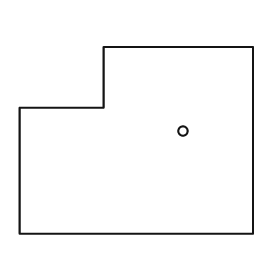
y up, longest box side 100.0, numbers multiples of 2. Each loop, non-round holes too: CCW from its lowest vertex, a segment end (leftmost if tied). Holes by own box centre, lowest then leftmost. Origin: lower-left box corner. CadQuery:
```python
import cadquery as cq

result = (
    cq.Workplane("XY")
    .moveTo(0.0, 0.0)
    .lineTo(100.0, 0.0)
    .lineTo(100.0, 80.0)
    .lineTo(36.0, 80.0)
    .lineTo(36.0, 54.0)
    .lineTo(0.0, 54.0)
    .close()
    .moveTo(70.0, 44.0)
    .circle(2.0)
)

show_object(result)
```